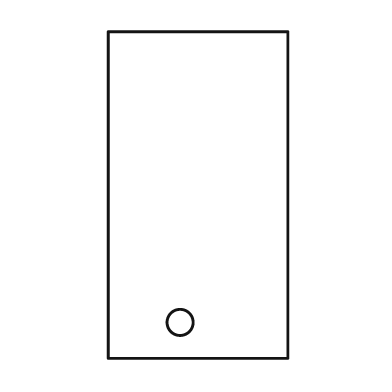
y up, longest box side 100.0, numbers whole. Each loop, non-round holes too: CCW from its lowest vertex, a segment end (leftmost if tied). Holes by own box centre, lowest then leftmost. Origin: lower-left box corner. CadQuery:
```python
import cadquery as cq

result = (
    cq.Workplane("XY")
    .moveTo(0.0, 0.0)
    .lineTo(55.0, 0.0)
    .lineTo(55.0, 100.0)
    .lineTo(0.0, 100.0)
    .close()
    .moveTo(22.0, 11.0)
    .circle(4.0)
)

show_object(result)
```